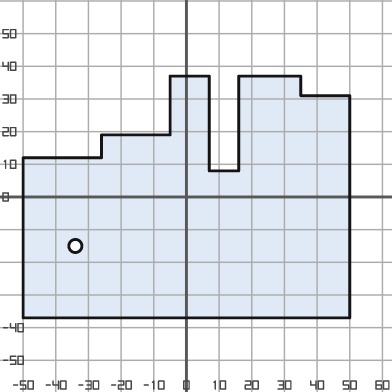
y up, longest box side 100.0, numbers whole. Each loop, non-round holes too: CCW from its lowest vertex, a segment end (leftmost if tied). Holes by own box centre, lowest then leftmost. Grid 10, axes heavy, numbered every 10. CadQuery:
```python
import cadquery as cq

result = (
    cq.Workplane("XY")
    .moveTo(-50.0, -37.0)
    .lineTo(50.0, -37.0)
    .lineTo(50.0, 31.0)
    .lineTo(35.0, 31.0)
    .lineTo(35.0, 37.0)
    .lineTo(16.0, 37.0)
    .lineTo(16.0, 8.0)
    .lineTo(7.0, 8.0)
    .lineTo(7.0, 37.0)
    .lineTo(-5.0, 37.0)
    .lineTo(-5.0, 19.0)
    .lineTo(-26.0, 19.0)
    .lineTo(-26.0, 12.0)
    .lineTo(-50.0, 12.0)
    .close()
    .moveTo(-34.0, -15.0)
    .circle(2.0)
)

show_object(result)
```